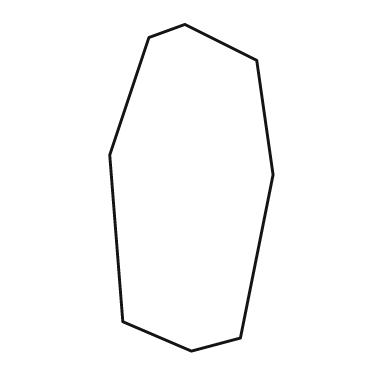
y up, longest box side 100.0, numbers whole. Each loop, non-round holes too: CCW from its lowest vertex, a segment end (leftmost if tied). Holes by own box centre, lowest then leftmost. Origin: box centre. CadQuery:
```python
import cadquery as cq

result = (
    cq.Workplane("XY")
    .moveTo(0.0, -50.0)
    .lineTo(15.0, -46.0)
    .lineTo(25.0, 4.0)
    .lineTo(20.0, 39.0)
    .lineTo(-2.0, 50.0)
    .lineTo(-13.0, 46.0)
    .lineTo(-25.0, 10.0)
    .lineTo(-21.0, -41.0)
    .close()
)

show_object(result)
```